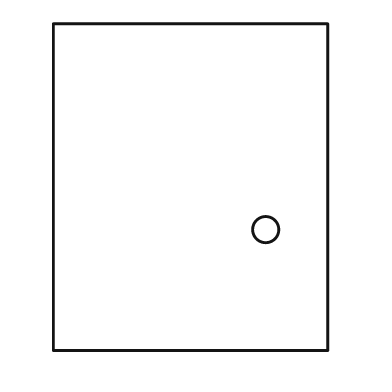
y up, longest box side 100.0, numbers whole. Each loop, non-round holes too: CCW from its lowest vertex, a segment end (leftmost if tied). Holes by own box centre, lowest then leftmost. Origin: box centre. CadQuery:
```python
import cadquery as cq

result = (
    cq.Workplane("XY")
    .moveTo(-42.0, -50.0)
    .lineTo(42.0, -50.0)
    .lineTo(42.0, 50.0)
    .lineTo(-42.0, 50.0)
    .close()
    .moveTo(23.0, -13.0)
    .circle(4.0)
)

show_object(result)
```